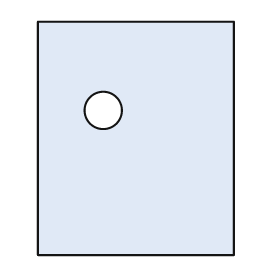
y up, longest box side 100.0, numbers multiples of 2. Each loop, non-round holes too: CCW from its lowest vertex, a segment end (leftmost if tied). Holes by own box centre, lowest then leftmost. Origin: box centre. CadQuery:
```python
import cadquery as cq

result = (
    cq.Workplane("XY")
    .moveTo(-42.0, -50.0)
    .lineTo(42.0, -50.0)
    .lineTo(42.0, 50.0)
    .lineTo(-42.0, 50.0)
    .close()
    .moveTo(-14.0, 12.0)
    .circle(8.0)
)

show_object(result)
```